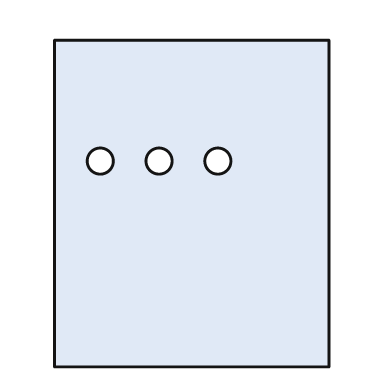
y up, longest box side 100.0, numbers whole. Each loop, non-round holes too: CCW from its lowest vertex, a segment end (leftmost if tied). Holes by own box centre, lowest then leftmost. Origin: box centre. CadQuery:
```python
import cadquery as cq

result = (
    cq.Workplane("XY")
    .moveTo(-42.0, -50.0)
    .lineTo(42.0, -50.0)
    .lineTo(42.0, 50.0)
    .lineTo(-42.0, 50.0)
    .close()
    .moveTo(-28.0, 13.0)
    .circle(4.0)
    .moveTo(-10.0, 13.0)
    .circle(4.0)
    .moveTo(8.0, 13.0)
    .circle(4.0)
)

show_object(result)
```